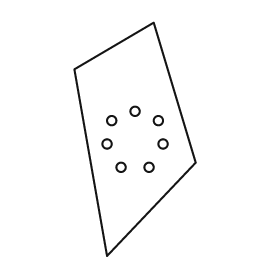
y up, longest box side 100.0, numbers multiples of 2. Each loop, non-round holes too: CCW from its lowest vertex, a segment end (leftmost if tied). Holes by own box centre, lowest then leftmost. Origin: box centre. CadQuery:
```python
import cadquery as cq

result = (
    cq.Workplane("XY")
    .moveTo(-12.0, -50.0)
    .lineTo(26.0, -10.0)
    .lineTo(8.0, 50.0)
    .lineTo(-26.0, 30.0)
    .close()
    .moveTo(-6.0, -12.0)
    .circle(2.0)
    .moveTo(6.0, -12.0)
    .circle(2.0)
    .moveTo(-12.0, -2.0)
    .circle(2.0)
    .moveTo(12.0, -2.0)
    .circle(2.0)
    .moveTo(-10.0, 8.0)
    .circle(2.0)
    .moveTo(10.0, 8.0)
    .circle(2.0)
    .moveTo(0.0, 12.0)
    .circle(2.0)
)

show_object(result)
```